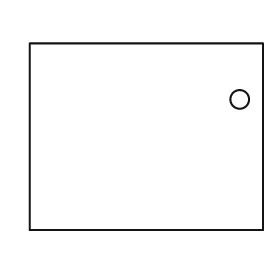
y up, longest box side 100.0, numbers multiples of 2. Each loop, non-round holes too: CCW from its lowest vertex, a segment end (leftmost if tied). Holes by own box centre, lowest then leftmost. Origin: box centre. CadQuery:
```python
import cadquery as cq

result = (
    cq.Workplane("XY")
    .moveTo(-50.0, -40.0)
    .lineTo(50.0, -40.0)
    .lineTo(50.0, 40.0)
    .lineTo(-50.0, 40.0)
    .close()
    .moveTo(40.0, 16.0)
    .circle(4.0)
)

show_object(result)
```